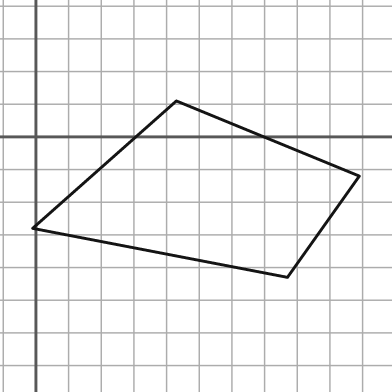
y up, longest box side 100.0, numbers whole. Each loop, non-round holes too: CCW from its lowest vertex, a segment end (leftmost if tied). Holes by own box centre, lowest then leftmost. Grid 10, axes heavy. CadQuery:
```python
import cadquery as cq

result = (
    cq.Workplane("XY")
    .moveTo(77.0, -43.0)
    .lineTo(99.0, -12.0)
    .lineTo(43.0, 11.0)
    .lineTo(-1.0, -28.0)
    .close()
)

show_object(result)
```